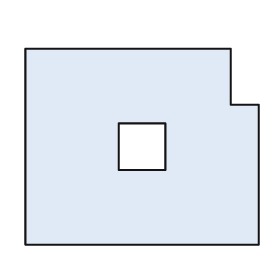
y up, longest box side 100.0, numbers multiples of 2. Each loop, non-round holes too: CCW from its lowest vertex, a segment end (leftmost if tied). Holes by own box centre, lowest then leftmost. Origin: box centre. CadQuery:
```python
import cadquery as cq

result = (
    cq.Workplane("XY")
    .moveTo(-50.0, -42.0)
    .lineTo(50.0, -42.0)
    .lineTo(50.0, 18.0)
    .lineTo(38.0, 18.0)
    .lineTo(38.0, 42.0)
    .lineTo(-50.0, 42.0)
    .close()
    .moveTo(-10.0, -10.0)
    .lineTo(10.0, -10.0)
    .lineTo(10.0, 10.0)
    .lineTo(-10.0, 10.0)
    .close()
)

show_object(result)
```